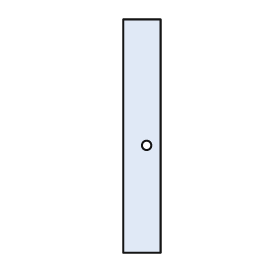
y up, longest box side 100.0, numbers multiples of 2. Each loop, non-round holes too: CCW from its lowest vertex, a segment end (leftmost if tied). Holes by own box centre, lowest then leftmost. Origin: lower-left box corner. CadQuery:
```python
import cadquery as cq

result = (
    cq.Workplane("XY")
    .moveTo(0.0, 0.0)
    .lineTo(16.0, 0.0)
    .lineTo(16.0, 100.0)
    .lineTo(0.0, 100.0)
    .close()
    .moveTo(10.0, 46.0)
    .circle(2.0)
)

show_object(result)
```